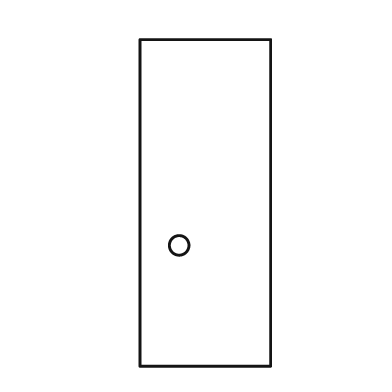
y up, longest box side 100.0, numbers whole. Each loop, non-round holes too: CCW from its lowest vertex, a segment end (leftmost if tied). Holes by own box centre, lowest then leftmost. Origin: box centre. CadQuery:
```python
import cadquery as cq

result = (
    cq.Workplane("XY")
    .moveTo(-20.0, -50.0)
    .lineTo(20.0, -50.0)
    .lineTo(20.0, 50.0)
    .lineTo(-20.0, 50.0)
    .close()
    .moveTo(-8.0, -13.0)
    .circle(3.0)
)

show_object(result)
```